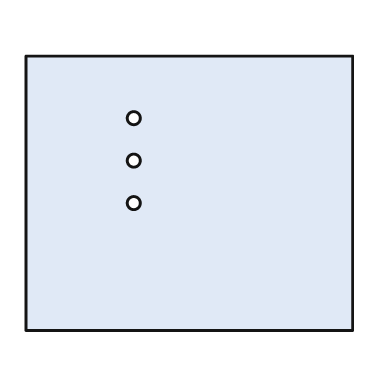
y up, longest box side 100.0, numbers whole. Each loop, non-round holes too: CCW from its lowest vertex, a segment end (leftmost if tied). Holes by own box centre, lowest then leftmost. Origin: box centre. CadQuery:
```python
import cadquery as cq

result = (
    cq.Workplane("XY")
    .moveTo(-50.0, -42.0)
    .lineTo(50.0, -42.0)
    .lineTo(50.0, 42.0)
    .lineTo(-50.0, 42.0)
    .close()
    .moveTo(-17.0, -3.0)
    .circle(2.0)
    .moveTo(-17.0, 10.0)
    .circle(2.0)
    .moveTo(-17.0, 23.0)
    .circle(2.0)
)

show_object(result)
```